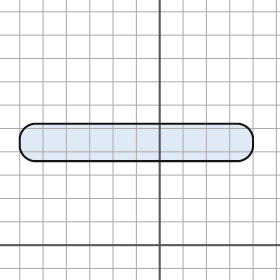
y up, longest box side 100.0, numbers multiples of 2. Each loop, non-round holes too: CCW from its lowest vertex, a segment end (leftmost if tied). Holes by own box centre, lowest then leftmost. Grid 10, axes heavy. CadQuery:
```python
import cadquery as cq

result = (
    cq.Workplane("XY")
    .moveTo(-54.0, 36.0)
    .lineTo(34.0, 36.0)
    .threePointArc((38.0, 38.0), (40.0, 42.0))
    .lineTo(40.0, 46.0)
    .threePointArc((38.0, 50.0), (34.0, 52.0))
    .lineTo(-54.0, 52.0)
    .threePointArc((-58.0, 50.0), (-60.0, 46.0))
    .lineTo(-60.0, 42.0)
    .threePointArc((-58.0, 38.0), (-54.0, 36.0))
    .close()
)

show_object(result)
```